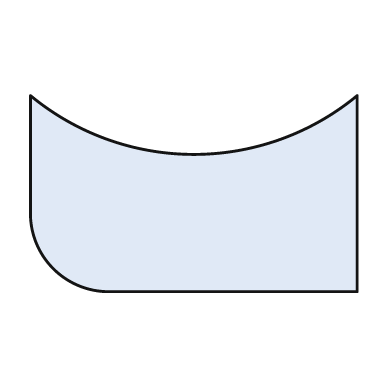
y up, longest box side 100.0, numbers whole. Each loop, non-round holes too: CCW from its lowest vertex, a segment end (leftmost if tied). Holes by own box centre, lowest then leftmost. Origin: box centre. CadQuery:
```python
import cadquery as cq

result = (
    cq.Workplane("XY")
    .moveTo(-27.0, -30.0)
    .lineTo(50.0, -30.0)
    .lineTo(50.0, 30.0)
    .threePointArc((0.0, 12.0), (-50.0, 30.0))
    .lineTo(-50.0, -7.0)
    .threePointArc((-43.0, -23.0), (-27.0, -30.0))
    .close()
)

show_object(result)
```